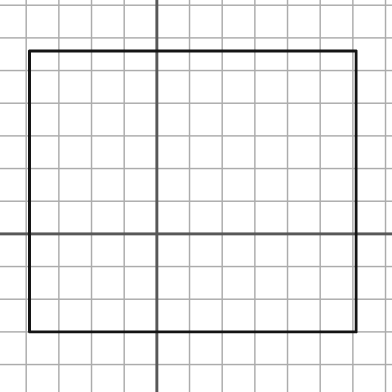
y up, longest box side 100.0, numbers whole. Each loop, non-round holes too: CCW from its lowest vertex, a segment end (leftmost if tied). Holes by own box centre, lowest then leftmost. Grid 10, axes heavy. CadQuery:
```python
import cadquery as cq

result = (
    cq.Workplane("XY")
    .moveTo(-39.0, -30.0)
    .lineTo(61.0, -30.0)
    .lineTo(61.0, 56.0)
    .lineTo(-39.0, 56.0)
    .close()
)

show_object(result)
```